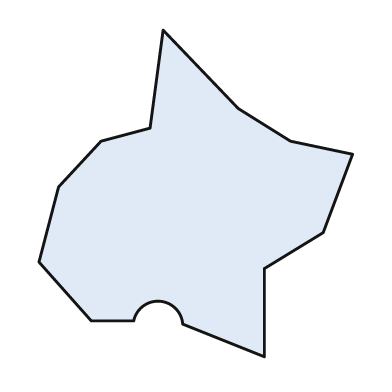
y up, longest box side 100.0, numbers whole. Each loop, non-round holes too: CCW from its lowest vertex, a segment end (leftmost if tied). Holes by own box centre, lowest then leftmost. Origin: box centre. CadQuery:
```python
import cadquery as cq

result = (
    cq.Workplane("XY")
    .moveTo(21.0, -50.0)
    .lineTo(21.0, -23.0)
    .lineTo(39.0, -12.0)
    .lineTo(48.0, 12.0)
    .lineTo(29.0, 16.0)
    .lineTo(13.0, 26.0)
    .lineTo(-10.0, 50.0)
    .lineTo(-14.0, 20.0)
    .lineTo(-29.0, 16.0)
    .lineTo(-42.0, 2.0)
    .lineTo(-48.0, -21.0)
    .lineTo(-32.0, -39.0)
    .lineTo(-19.0, -39.0)
    .threePointArc((-11.0, -33.0), (-4.0, -40.0))
    .close()
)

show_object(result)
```